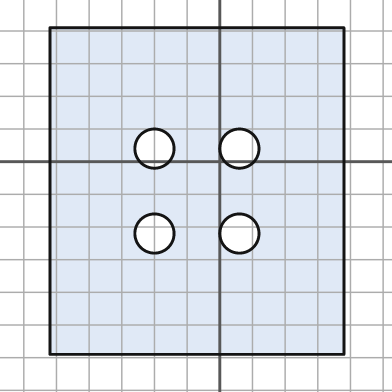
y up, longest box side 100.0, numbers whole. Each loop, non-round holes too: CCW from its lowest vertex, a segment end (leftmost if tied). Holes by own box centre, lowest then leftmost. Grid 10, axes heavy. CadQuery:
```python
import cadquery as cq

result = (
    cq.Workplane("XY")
    .moveTo(-52.0, -59.0)
    .lineTo(38.0, -59.0)
    .lineTo(38.0, 41.0)
    .lineTo(-52.0, 41.0)
    .close()
    .moveTo(-20.0, -22.0)
    .circle(6.0)
    .moveTo(6.0, -22.0)
    .circle(6.0)
    .moveTo(-20.0, 4.0)
    .circle(6.0)
    .moveTo(6.0, 4.0)
    .circle(6.0)
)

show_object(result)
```